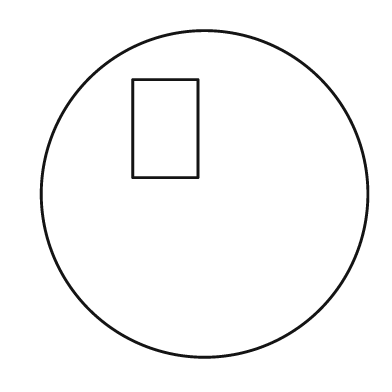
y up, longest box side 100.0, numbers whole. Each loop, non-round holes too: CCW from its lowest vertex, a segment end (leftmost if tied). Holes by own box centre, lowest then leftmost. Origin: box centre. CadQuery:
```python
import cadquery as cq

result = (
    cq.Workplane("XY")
    .moveTo(0.0, 0.0)
    .circle(50.0)
    .moveTo(-22.0, 5.0)
    .lineTo(-2.0, 5.0)
    .lineTo(-2.0, 35.0)
    .lineTo(-22.0, 35.0)
    .close()
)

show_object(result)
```